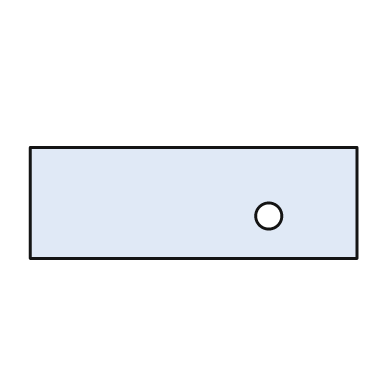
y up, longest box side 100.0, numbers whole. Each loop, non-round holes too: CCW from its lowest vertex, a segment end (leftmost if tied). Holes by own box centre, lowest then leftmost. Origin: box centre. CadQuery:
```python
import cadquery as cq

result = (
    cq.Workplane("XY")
    .moveTo(-50.0, -17.0)
    .lineTo(50.0, -17.0)
    .lineTo(50.0, 17.0)
    .lineTo(-50.0, 17.0)
    .close()
    .moveTo(23.0, -4.0)
    .circle(4.0)
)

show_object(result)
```